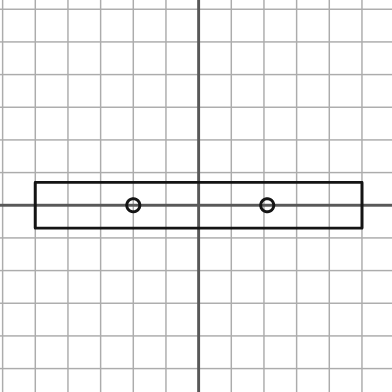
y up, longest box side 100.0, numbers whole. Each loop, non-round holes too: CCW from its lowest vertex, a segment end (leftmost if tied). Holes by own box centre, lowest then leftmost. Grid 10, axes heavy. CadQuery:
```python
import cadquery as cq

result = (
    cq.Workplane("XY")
    .moveTo(-50.0, -7.0)
    .lineTo(50.0, -7.0)
    .lineTo(50.0, 7.0)
    .lineTo(-50.0, 7.0)
    .close()
    .moveTo(-20.0, 0.0)
    .circle(2.0)
    .moveTo(21.0, 0.0)
    .circle(2.0)
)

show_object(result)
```